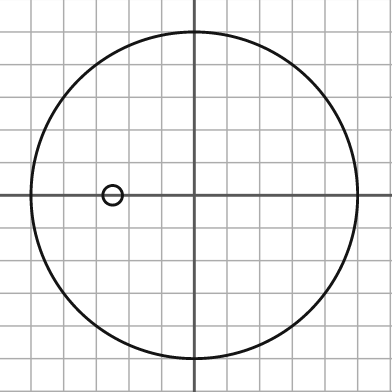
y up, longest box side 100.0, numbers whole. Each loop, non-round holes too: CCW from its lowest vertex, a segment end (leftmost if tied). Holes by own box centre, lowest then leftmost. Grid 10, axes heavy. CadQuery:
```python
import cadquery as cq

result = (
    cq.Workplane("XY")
    .moveTo(0.0, 0.0)
    .circle(50.0)
    .moveTo(-25.0, 0.0)
    .circle(3.0)
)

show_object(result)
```